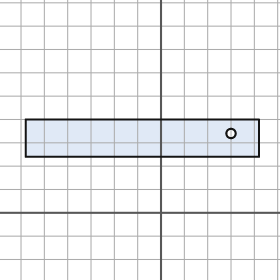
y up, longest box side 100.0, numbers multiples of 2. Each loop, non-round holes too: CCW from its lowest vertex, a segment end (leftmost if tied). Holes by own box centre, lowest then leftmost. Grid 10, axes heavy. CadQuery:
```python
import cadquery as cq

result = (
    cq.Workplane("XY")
    .moveTo(-58.0, 24.0)
    .lineTo(42.0, 24.0)
    .lineTo(42.0, 40.0)
    .lineTo(-58.0, 40.0)
    .close()
    .moveTo(30.0, 34.0)
    .circle(2.0)
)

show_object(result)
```